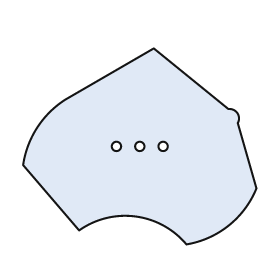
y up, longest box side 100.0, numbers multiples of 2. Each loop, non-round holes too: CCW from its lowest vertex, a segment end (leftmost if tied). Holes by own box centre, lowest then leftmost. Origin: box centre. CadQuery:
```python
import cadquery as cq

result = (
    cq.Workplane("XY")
    .moveTo(20.0, -42.0)
    .threePointArc((38.0, -34.0), (50.0, -18.0))
    .lineTo(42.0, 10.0)
    .threePointArc((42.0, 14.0), (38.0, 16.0))
    .lineTo(6.0, 42.0)
    .lineTo(-32.0, 20.0)
    .threePointArc((-44.0, 8.0), (-50.0, -8.0))
    .lineTo(-26.0, -36.0)
    .threePointArc((-2.0, -30.0), (20.0, -42.0))
    .close()
    .moveTo(-10.0, 0.0)
    .circle(2.0)
    .moveTo(0.0, 0.0)
    .circle(2.0)
    .moveTo(10.0, 0.0)
    .circle(2.0)
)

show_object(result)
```